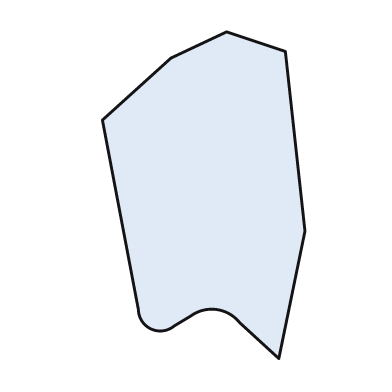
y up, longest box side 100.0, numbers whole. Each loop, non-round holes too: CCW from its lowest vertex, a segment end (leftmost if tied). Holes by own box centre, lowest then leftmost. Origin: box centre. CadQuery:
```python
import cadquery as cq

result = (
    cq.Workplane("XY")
    .moveTo(23.0, -50.0)
    .lineTo(31.0, -11.0)
    .lineTo(25.0, 44.0)
    .lineTo(7.0, 50.0)
    .lineTo(-10.0, 42.0)
    .lineTo(-31.0, 23.0)
    .lineTo(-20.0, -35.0)
    .threePointArc((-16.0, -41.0), (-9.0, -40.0))
    .lineTo(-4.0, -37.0)
    .threePointArc((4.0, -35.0), (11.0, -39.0))
    .close()
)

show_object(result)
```